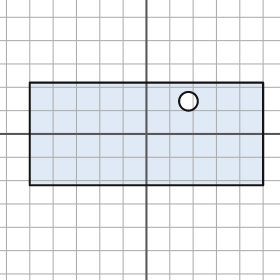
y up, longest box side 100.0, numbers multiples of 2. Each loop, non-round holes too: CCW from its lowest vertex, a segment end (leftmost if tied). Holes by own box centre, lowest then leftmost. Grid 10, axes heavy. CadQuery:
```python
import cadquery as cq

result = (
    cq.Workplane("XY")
    .moveTo(-50.0, -22.0)
    .lineTo(50.0, -22.0)
    .lineTo(50.0, 22.0)
    .lineTo(-50.0, 22.0)
    .close()
    .moveTo(18.0, 14.0)
    .circle(4.0)
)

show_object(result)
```